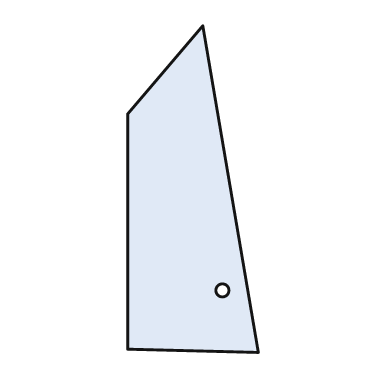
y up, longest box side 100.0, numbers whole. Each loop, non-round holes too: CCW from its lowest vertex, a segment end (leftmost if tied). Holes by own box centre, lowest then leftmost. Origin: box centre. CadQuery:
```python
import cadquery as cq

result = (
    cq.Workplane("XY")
    .moveTo(20.0, -50.0)
    .lineTo(3.0, 50.0)
    .lineTo(-20.0, 23.0)
    .lineTo(-20.0, -49.0)
    .close()
    .moveTo(9.0, -31.0)
    .circle(2.0)
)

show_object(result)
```